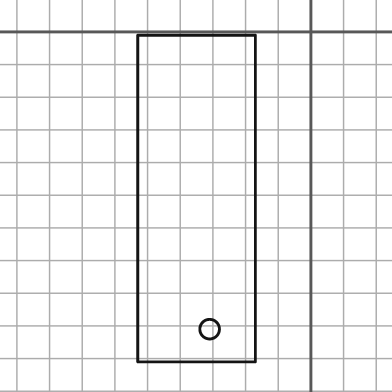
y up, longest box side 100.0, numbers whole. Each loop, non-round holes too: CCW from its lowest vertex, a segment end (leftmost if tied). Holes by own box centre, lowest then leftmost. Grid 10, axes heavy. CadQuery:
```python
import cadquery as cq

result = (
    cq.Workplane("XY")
    .moveTo(-53.0, -101.0)
    .lineTo(-17.0, -101.0)
    .lineTo(-17.0, -1.0)
    .lineTo(-53.0, -1.0)
    .close()
    .moveTo(-31.0, -91.0)
    .circle(3.0)
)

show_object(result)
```